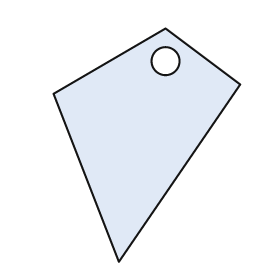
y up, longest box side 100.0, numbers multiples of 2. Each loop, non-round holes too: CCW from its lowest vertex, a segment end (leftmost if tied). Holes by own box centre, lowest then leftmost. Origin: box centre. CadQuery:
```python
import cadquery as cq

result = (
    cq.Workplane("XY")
    .moveTo(-12.0, -50.0)
    .lineTo(40.0, 26.0)
    .lineTo(8.0, 50.0)
    .lineTo(-40.0, 22.0)
    .close()
    .moveTo(8.0, 36.0)
    .circle(6.0)
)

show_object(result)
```